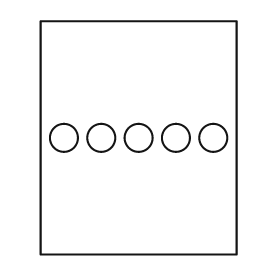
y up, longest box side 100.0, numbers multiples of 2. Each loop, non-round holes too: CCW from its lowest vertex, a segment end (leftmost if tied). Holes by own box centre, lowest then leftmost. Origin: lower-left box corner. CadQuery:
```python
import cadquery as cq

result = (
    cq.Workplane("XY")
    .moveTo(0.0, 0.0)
    .lineTo(84.0, 0.0)
    .lineTo(84.0, 100.0)
    .lineTo(0.0, 100.0)
    .close()
    .moveTo(10.0, 50.0)
    .circle(6.0)
    .moveTo(26.0, 50.0)
    .circle(6.0)
    .moveTo(42.0, 50.0)
    .circle(6.0)
    .moveTo(58.0, 50.0)
    .circle(6.0)
    .moveTo(74.0, 50.0)
    .circle(6.0)
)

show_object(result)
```